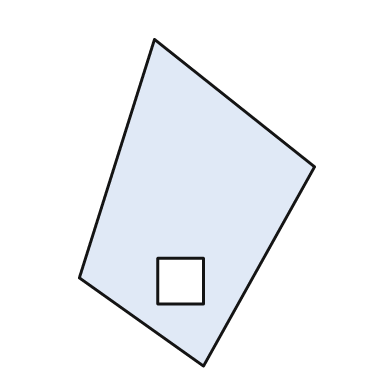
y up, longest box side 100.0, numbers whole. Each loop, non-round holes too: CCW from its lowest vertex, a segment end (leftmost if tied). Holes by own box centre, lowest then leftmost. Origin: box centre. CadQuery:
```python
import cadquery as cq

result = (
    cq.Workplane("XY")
    .moveTo(2.0, -50.0)
    .lineTo(36.0, 11.0)
    .lineTo(-13.0, 50.0)
    .lineTo(-36.0, -23.0)
    .close()
    .moveTo(-12.0, -31.0)
    .lineTo(2.0, -31.0)
    .lineTo(2.0, -17.0)
    .lineTo(-12.0, -17.0)
    .close()
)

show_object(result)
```